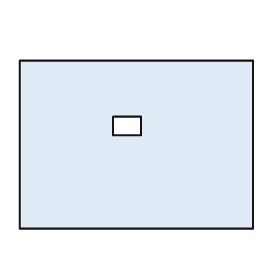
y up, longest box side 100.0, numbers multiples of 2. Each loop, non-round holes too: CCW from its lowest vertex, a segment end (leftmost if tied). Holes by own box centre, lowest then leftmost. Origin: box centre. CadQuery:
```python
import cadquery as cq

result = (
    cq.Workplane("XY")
    .moveTo(-50.0, -36.0)
    .lineTo(50.0, -36.0)
    .lineTo(50.0, 36.0)
    .lineTo(-50.0, 36.0)
    .close()
    .moveTo(-10.0, 4.0)
    .lineTo(2.0, 4.0)
    .lineTo(2.0, 12.0)
    .lineTo(-10.0, 12.0)
    .close()
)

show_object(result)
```